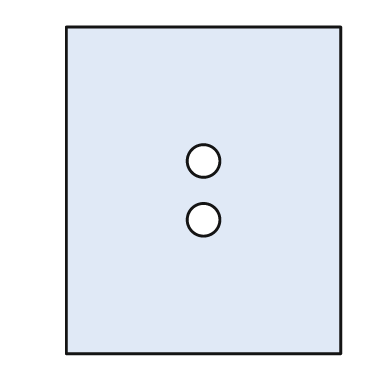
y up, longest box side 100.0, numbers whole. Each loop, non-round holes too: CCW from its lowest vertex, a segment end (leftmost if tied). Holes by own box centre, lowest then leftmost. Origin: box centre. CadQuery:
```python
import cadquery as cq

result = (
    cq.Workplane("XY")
    .moveTo(-42.0, -50.0)
    .lineTo(42.0, -50.0)
    .lineTo(42.0, 50.0)
    .lineTo(-42.0, 50.0)
    .close()
    .moveTo(0.0, -9.0)
    .circle(5.0)
    .moveTo(0.0, 9.0)
    .circle(5.0)
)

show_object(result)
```